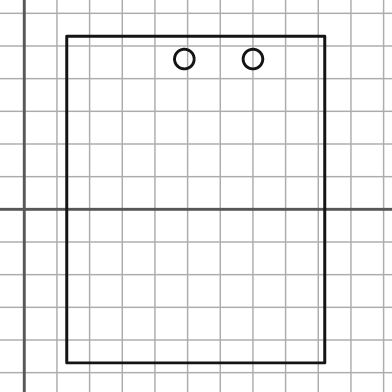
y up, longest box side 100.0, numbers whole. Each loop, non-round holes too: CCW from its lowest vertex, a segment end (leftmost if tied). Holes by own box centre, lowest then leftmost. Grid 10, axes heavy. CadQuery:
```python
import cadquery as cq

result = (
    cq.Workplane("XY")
    .moveTo(13.0, -47.0)
    .lineTo(92.0, -47.0)
    .lineTo(92.0, 53.0)
    .lineTo(13.0, 53.0)
    .close()
    .moveTo(49.0, 46.0)
    .circle(3.0)
    .moveTo(70.0, 46.0)
    .circle(3.0)
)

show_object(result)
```